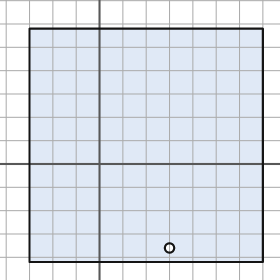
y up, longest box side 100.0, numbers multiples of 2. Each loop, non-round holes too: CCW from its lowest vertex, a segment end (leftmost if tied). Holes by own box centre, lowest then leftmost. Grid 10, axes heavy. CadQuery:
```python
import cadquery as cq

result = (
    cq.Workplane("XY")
    .moveTo(-30.0, -42.0)
    .lineTo(70.0, -42.0)
    .lineTo(70.0, 58.0)
    .lineTo(-30.0, 58.0)
    .close()
    .moveTo(30.0, -36.0)
    .circle(2.0)
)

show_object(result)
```